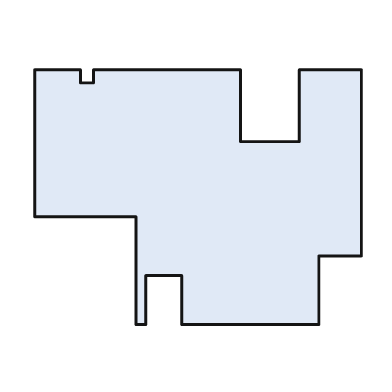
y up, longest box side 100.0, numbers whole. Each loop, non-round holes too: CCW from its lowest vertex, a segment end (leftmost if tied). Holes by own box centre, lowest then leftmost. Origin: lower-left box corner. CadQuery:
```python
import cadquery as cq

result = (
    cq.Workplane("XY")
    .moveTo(31.0, 0.0)
    .lineTo(34.0, 0.0)
    .lineTo(34.0, 15.0)
    .lineTo(45.0, 15.0)
    .lineTo(45.0, 0.0)
    .lineTo(87.0, 0.0)
    .lineTo(87.0, 21.0)
    .lineTo(100.0, 21.0)
    .lineTo(100.0, 78.0)
    .lineTo(81.0, 78.0)
    .lineTo(81.0, 56.0)
    .lineTo(63.0, 56.0)
    .lineTo(63.0, 78.0)
    .lineTo(18.0, 78.0)
    .lineTo(18.0, 74.0)
    .lineTo(14.0, 74.0)
    .lineTo(14.0, 78.0)
    .lineTo(0.0, 78.0)
    .lineTo(0.0, 33.0)
    .lineTo(31.0, 33.0)
    .close()
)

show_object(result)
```